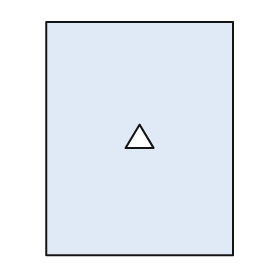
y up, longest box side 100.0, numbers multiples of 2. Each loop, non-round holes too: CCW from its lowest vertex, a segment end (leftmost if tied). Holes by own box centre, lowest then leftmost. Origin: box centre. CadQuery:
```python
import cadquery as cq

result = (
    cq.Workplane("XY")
    .moveTo(-40.0, -50.0)
    .lineTo(40.0, -50.0)
    .lineTo(40.0, 50.0)
    .lineTo(-40.0, 50.0)
    .close()
    .moveTo(-6.0, -4.0)
    .lineTo(6.0, -4.0)
    .lineTo(0.0, 6.0)
    .close()
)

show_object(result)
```